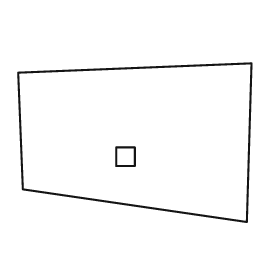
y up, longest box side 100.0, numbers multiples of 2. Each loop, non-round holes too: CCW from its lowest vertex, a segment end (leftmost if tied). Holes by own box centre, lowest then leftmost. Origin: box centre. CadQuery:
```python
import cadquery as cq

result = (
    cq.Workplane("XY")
    .moveTo(48.0, -34.0)
    .lineTo(50.0, 34.0)
    .lineTo(-50.0, 30.0)
    .lineTo(-48.0, -20.0)
    .close()
    .moveTo(-8.0, -10.0)
    .lineTo(0.0, -10.0)
    .lineTo(0.0, -2.0)
    .lineTo(-8.0, -2.0)
    .close()
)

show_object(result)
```